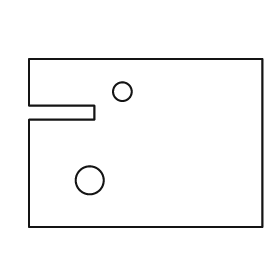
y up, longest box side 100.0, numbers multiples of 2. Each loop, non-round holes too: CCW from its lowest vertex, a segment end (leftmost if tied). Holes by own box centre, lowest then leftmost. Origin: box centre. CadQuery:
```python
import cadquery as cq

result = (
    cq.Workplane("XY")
    .moveTo(-50.0, -36.0)
    .lineTo(50.0, -36.0)
    .lineTo(50.0, 36.0)
    .lineTo(-50.0, 36.0)
    .lineTo(-50.0, 16.0)
    .lineTo(-22.0, 16.0)
    .lineTo(-22.0, 10.0)
    .lineTo(-50.0, 10.0)
    .close()
    .moveTo(-24.0, -16.0)
    .circle(6.0)
    .moveTo(-10.0, 22.0)
    .circle(4.0)
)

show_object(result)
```